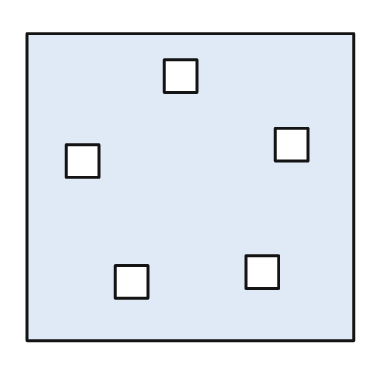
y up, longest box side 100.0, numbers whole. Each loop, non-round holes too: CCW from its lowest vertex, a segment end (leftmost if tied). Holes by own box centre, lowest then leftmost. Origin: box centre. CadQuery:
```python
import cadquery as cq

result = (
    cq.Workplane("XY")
    .moveTo(-50.0, -47.0)
    .lineTo(50.0, -47.0)
    .lineTo(50.0, 47.0)
    .lineTo(-50.0, 47.0)
    .close()
    .moveTo(-23.0, -34.0)
    .lineTo(-13.0, -34.0)
    .lineTo(-13.0, -24.0)
    .lineTo(-23.0, -24.0)
    .close()
    .moveTo(17.0, -31.0)
    .lineTo(27.0, -31.0)
    .lineTo(27.0, -21.0)
    .lineTo(17.0, -21.0)
    .close()
    .moveTo(-38.0, 3.0)
    .lineTo(-28.0, 3.0)
    .lineTo(-28.0, 13.0)
    .lineTo(-38.0, 13.0)
    .close()
    .moveTo(26.0, 8.0)
    .lineTo(36.0, 8.0)
    .lineTo(36.0, 18.0)
    .lineTo(26.0, 18.0)
    .close()
    .moveTo(-8.0, 29.0)
    .lineTo(2.0, 29.0)
    .lineTo(2.0, 39.0)
    .lineTo(-8.0, 39.0)
    .close()
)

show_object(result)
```